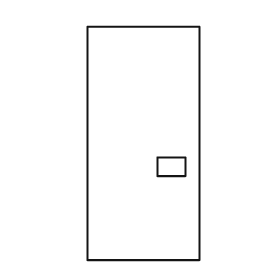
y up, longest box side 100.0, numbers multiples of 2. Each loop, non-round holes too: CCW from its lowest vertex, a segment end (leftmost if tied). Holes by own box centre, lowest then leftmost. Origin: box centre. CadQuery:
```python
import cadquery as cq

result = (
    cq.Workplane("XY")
    .moveTo(-24.0, -50.0)
    .lineTo(24.0, -50.0)
    .lineTo(24.0, 50.0)
    .lineTo(-24.0, 50.0)
    .close()
    .moveTo(6.0, -14.0)
    .lineTo(18.0, -14.0)
    .lineTo(18.0, -6.0)
    .lineTo(6.0, -6.0)
    .close()
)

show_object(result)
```